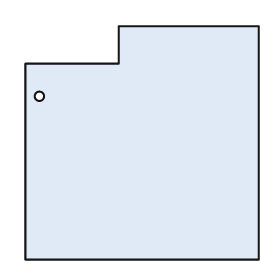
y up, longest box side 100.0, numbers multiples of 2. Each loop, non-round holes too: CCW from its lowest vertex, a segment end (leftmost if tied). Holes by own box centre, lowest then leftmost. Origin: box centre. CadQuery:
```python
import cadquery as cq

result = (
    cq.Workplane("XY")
    .moveTo(-50.0, -50.0)
    .lineTo(50.0, -50.0)
    .lineTo(50.0, 50.0)
    .lineTo(-10.0, 50.0)
    .lineTo(-10.0, 34.0)
    .lineTo(-50.0, 34.0)
    .close()
    .moveTo(-44.0, 20.0)
    .circle(2.0)
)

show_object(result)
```